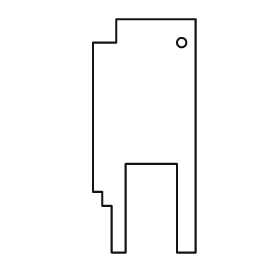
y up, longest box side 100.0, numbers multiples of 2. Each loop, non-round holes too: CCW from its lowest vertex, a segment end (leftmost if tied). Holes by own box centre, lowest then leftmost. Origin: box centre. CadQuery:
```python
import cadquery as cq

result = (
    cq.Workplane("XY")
    .moveTo(-14.0, -50.0)
    .lineTo(-8.0, -50.0)
    .lineTo(-8.0, -12.0)
    .lineTo(14.0, -12.0)
    .lineTo(14.0, -50.0)
    .lineTo(22.0, -50.0)
    .lineTo(22.0, 50.0)
    .lineTo(-12.0, 50.0)
    .lineTo(-12.0, 40.0)
    .lineTo(-22.0, 40.0)
    .lineTo(-22.0, -24.0)
    .lineTo(-18.0, -24.0)
    .lineTo(-18.0, -30.0)
    .lineTo(-14.0, -30.0)
    .close()
    .moveTo(16.0, 40.0)
    .circle(2.0)
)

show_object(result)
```